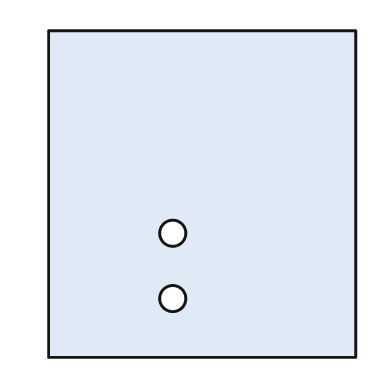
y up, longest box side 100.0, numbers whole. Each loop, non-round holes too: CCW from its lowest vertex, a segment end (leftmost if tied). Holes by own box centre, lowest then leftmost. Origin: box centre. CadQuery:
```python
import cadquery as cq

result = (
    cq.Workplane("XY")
    .moveTo(-47.0, -50.0)
    .lineTo(47.0, -50.0)
    .lineTo(47.0, 50.0)
    .lineTo(-47.0, 50.0)
    .close()
    .moveTo(-9.0, -32.0)
    .circle(4.0)
    .moveTo(-9.0, -12.0)
    .circle(4.0)
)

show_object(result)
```